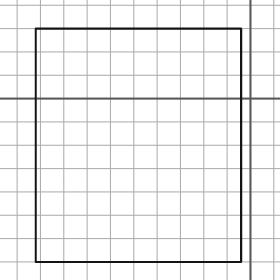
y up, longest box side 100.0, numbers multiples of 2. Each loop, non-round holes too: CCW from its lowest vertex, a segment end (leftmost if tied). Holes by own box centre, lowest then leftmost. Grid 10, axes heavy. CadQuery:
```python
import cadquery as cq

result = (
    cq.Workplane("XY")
    .moveTo(-92.0, -70.0)
    .lineTo(-4.0, -70.0)
    .lineTo(-4.0, 30.0)
    .lineTo(-92.0, 30.0)
    .close()
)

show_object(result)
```